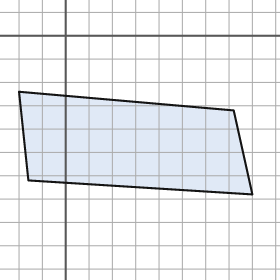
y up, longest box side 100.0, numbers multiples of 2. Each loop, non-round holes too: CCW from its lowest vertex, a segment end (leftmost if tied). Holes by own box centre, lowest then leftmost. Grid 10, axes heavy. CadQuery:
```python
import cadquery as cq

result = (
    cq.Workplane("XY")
    .moveTo(80.0, -68.0)
    .lineTo(72.0, -32.0)
    .lineTo(-20.0, -24.0)
    .lineTo(-16.0, -62.0)
    .close()
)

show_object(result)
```